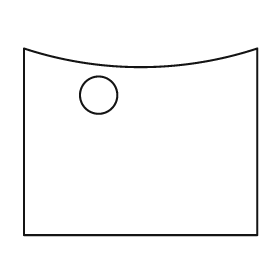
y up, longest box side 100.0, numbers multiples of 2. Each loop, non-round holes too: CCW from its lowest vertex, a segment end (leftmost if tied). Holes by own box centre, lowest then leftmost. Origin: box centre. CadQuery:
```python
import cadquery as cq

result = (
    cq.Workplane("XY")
    .moveTo(-50.0, -40.0)
    .lineTo(50.0, -40.0)
    .lineTo(50.0, 40.0)
    .threePointArc((0.0, 32.0), (-50.0, 40.0))
    .close()
    .moveTo(-18.0, 20.0)
    .circle(8.0)
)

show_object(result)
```